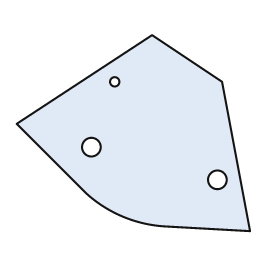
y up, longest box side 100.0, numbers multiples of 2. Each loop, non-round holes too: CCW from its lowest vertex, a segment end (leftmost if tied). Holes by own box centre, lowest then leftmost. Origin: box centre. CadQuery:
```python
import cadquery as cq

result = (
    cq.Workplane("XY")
    .moveTo(50.0, -42.0)
    .lineTo(38.0, 22.0)
    .lineTo(8.0, 42.0)
    .lineTo(-50.0, 4.0)
    .lineTo(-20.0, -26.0)
    .threePointArc((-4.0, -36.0), (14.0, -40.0))
    .close()
    .moveTo(36.0, -20.0)
    .circle(4.0)
    .moveTo(-18.0, -6.0)
    .circle(4.0)
    .moveTo(-8.0, 22.0)
    .circle(2.0)
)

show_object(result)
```